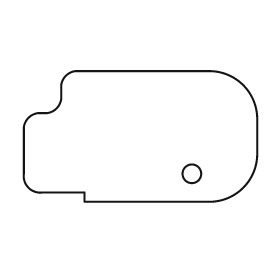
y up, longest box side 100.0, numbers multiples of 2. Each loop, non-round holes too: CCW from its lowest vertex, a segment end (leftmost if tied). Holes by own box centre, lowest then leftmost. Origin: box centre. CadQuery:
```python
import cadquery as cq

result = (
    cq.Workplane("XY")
    .moveTo(-24.0, -28.0)
    .lineTo(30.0, -28.0)
    .threePointArc((44.0, -22.0), (50.0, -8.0))
    .lineTo(50.0, 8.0)
    .threePointArc((44.0, 22.0), (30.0, 28.0))
    .lineTo(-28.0, 28.0)
    .threePointArc((-32.0, 26.0), (-34.0, 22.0))
    .lineTo(-34.0, 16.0)
    .threePointArc((-36.0, 12.0), (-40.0, 10.0))
    .lineTo(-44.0, 10.0)
    .threePointArc((-48.0, 8.0), (-50.0, 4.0))
    .lineTo(-50.0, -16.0)
    .threePointArc((-48.0, -22.0), (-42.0, -24.0))
    .lineTo(-24.0, -24.0)
    .close()
    .moveTo(22.0, -16.0)
    .circle(4.0)
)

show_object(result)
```